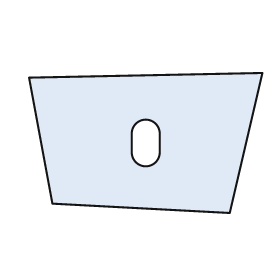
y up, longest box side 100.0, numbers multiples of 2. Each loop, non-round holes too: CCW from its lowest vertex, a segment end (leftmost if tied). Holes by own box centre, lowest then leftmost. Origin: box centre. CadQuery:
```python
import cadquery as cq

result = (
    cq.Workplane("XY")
    .moveTo(36.0, -30.0)
    .lineTo(50.0, 30.0)
    .lineTo(-50.0, 28.0)
    .lineTo(-40.0, -26.0)
    .close()
    .moveTo(-6.0, -4.0)
    .threePointArc((0.0, -10.0), (6.0, -4.0))
    .lineTo(6.0, 4.0)
    .threePointArc((0.0, 10.0), (-6.0, 4.0))
    .close()
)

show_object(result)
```